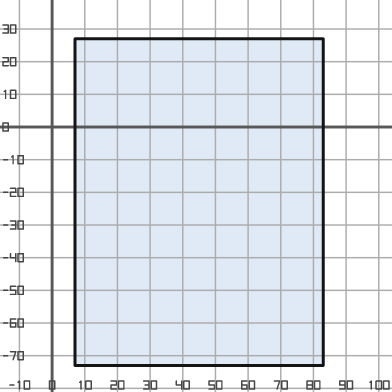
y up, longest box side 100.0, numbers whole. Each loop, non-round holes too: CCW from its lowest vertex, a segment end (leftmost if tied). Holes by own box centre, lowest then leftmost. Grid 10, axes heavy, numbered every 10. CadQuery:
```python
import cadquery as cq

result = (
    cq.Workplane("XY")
    .moveTo(7.0, -73.0)
    .lineTo(83.0, -73.0)
    .lineTo(83.0, 27.0)
    .lineTo(7.0, 27.0)
    .close()
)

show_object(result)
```